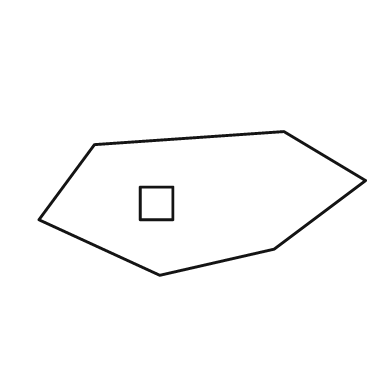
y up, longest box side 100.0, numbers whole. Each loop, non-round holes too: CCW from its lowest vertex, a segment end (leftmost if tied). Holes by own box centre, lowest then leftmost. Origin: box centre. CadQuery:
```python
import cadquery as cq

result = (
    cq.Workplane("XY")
    .moveTo(-13.0, -22.0)
    .lineTo(22.0, -14.0)
    .lineTo(50.0, 7.0)
    .lineTo(25.0, 22.0)
    .lineTo(-33.0, 18.0)
    .lineTo(-50.0, -5.0)
    .close()
    .moveTo(-19.0, -5.0)
    .lineTo(-9.0, -5.0)
    .lineTo(-9.0, 5.0)
    .lineTo(-19.0, 5.0)
    .close()
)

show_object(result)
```